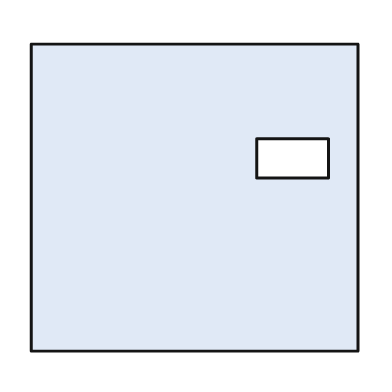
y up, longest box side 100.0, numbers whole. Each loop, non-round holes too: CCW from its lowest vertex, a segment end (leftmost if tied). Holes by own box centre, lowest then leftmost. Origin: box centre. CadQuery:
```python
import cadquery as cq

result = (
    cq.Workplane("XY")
    .moveTo(-50.0, -47.0)
    .lineTo(50.0, -47.0)
    .lineTo(50.0, 47.0)
    .lineTo(-50.0, 47.0)
    .close()
    .moveTo(19.0, 6.0)
    .lineTo(41.0, 6.0)
    .lineTo(41.0, 18.0)
    .lineTo(19.0, 18.0)
    .close()
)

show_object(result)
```